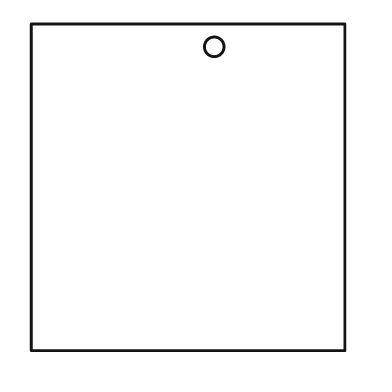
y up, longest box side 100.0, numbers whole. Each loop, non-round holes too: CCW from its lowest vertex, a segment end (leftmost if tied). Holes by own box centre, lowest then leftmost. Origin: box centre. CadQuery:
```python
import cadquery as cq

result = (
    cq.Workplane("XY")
    .moveTo(-48.0, -50.0)
    .lineTo(48.0, -50.0)
    .lineTo(48.0, 50.0)
    .lineTo(-48.0, 50.0)
    .close()
    .moveTo(8.0, 43.0)
    .circle(3.0)
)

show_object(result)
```